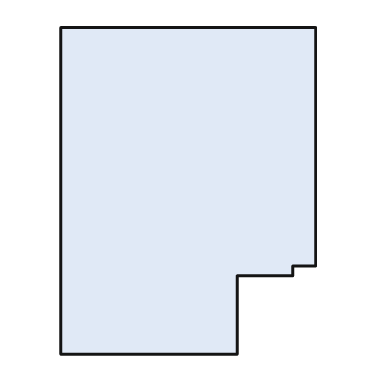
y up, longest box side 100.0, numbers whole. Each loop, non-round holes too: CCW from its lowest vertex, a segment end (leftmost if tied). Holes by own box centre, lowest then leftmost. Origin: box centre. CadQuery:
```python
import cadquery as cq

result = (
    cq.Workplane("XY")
    .moveTo(-39.0, -50.0)
    .lineTo(15.0, -50.0)
    .lineTo(15.0, -26.0)
    .lineTo(32.0, -26.0)
    .lineTo(32.0, -23.0)
    .lineTo(39.0, -23.0)
    .lineTo(39.0, 50.0)
    .lineTo(-39.0, 50.0)
    .close()
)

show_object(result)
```